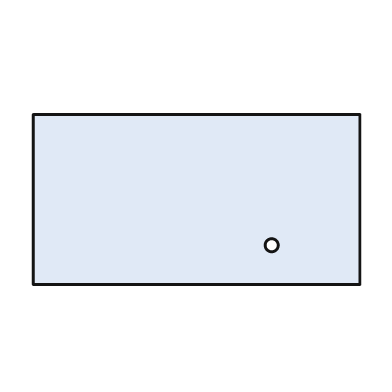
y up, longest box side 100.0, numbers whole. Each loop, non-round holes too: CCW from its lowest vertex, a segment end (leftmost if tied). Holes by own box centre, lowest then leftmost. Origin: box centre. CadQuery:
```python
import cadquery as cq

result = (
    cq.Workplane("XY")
    .moveTo(-50.0, -26.0)
    .lineTo(50.0, -26.0)
    .lineTo(50.0, 26.0)
    .lineTo(-50.0, 26.0)
    .close()
    .moveTo(23.0, -14.0)
    .circle(2.0)
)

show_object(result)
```